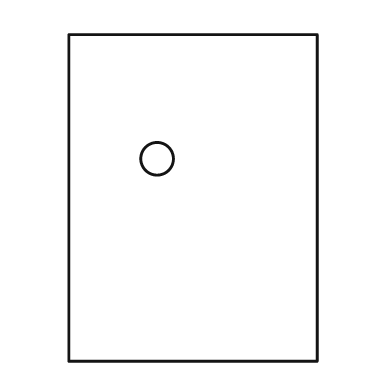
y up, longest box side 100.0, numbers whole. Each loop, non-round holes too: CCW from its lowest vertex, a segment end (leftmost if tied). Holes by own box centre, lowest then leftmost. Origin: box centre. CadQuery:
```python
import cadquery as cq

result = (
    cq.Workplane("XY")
    .moveTo(-38.0, -50.0)
    .lineTo(38.0, -50.0)
    .lineTo(38.0, 50.0)
    .lineTo(-38.0, 50.0)
    .close()
    .moveTo(-11.0, 12.0)
    .circle(5.0)
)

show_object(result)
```